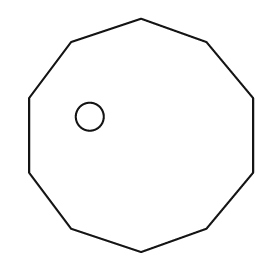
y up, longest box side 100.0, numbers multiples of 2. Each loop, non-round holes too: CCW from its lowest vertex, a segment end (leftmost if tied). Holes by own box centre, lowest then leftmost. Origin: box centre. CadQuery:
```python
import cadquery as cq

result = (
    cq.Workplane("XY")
    .moveTo(0.0, -50.0)
    .lineTo(28.0, -40.0)
    .lineTo(48.0, -16.0)
    .lineTo(48.0, 16.0)
    .lineTo(28.0, 40.0)
    .lineTo(0.0, 50.0)
    .lineTo(-30.0, 40.0)
    .lineTo(-48.0, 16.0)
    .lineTo(-48.0, -16.0)
    .lineTo(-30.0, -40.0)
    .close()
    .moveTo(-22.0, 8.0)
    .circle(6.0)
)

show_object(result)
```